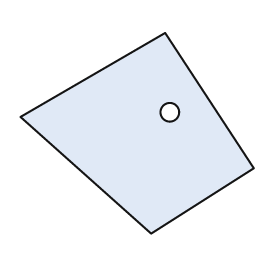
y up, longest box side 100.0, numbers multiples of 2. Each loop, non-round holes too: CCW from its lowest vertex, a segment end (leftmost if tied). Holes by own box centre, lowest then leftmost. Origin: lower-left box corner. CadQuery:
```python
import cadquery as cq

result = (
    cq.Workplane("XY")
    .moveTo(56.0, 0.0)
    .lineTo(100.0, 28.0)
    .lineTo(62.0, 86.0)
    .lineTo(0.0, 50.0)
    .close()
    .moveTo(64.0, 52.0)
    .circle(4.0)
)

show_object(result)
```